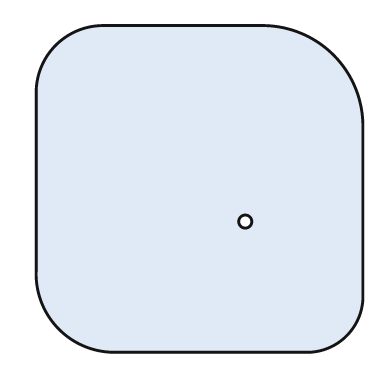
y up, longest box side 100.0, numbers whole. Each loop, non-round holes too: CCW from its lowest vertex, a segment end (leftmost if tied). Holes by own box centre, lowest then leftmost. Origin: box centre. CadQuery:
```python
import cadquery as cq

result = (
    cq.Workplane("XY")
    .moveTo(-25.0, -50.0)
    .lineTo(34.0, -50.0)
    .threePointArc((45.0, -45.0), (50.0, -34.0))
    .lineTo(50.0, 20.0)
    .threePointArc((41.0, 41.0), (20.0, 50.0))
    .lineTo(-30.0, 50.0)
    .threePointArc((-44.0, 44.0), (-50.0, 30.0))
    .lineTo(-50.0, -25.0)
    .threePointArc((-43.0, -43.0), (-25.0, -50.0))
    .close()
    .moveTo(14.0, -10.0)
    .circle(2.0)
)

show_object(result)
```